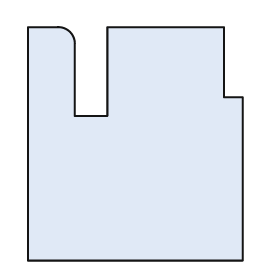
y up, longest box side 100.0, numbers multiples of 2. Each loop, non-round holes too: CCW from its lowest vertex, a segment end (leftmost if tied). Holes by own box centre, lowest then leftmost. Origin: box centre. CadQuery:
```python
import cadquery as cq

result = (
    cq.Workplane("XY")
    .moveTo(-46.0, -50.0)
    .lineTo(46.0, -50.0)
    .lineTo(46.0, 20.0)
    .lineTo(38.0, 20.0)
    .lineTo(38.0, 50.0)
    .lineTo(-12.0, 50.0)
    .lineTo(-12.0, 12.0)
    .lineTo(-26.0, 12.0)
    .lineTo(-26.0, 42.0)
    .threePointArc((-28.0, 48.0), (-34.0, 50.0))
    .lineTo(-46.0, 50.0)
    .close()
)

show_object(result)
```